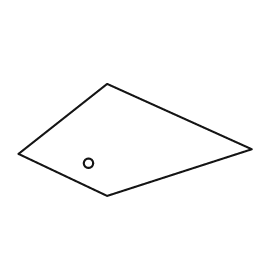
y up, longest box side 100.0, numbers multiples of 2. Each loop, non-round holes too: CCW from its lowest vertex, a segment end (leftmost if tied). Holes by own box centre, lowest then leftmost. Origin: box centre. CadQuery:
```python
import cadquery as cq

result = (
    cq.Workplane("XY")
    .moveTo(-12.0, -24.0)
    .lineTo(50.0, -4.0)
    .lineTo(-12.0, 24.0)
    .lineTo(-50.0, -6.0)
    .close()
    .moveTo(-20.0, -10.0)
    .circle(2.0)
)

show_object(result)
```